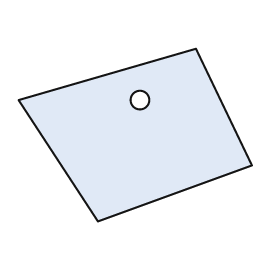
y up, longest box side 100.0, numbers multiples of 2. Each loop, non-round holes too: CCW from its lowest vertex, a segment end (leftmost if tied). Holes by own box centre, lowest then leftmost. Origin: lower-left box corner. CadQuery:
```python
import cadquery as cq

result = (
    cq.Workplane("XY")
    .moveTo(34.0, 0.0)
    .lineTo(100.0, 24.0)
    .lineTo(76.0, 74.0)
    .lineTo(0.0, 52.0)
    .close()
    .moveTo(52.0, 52.0)
    .circle(4.0)
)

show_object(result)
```